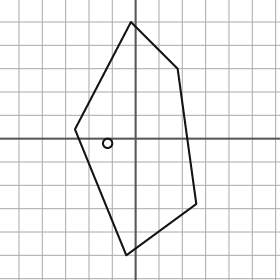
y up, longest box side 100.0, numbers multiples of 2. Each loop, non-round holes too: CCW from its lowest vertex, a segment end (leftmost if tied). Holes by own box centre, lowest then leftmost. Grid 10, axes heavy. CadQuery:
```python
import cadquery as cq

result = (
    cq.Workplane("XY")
    .moveTo(-4.0, -50.0)
    .lineTo(26.0, -28.0)
    .lineTo(18.0, 30.0)
    .lineTo(-2.0, 50.0)
    .lineTo(-26.0, 4.0)
    .close()
    .moveTo(-12.0, -2.0)
    .circle(2.0)
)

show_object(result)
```